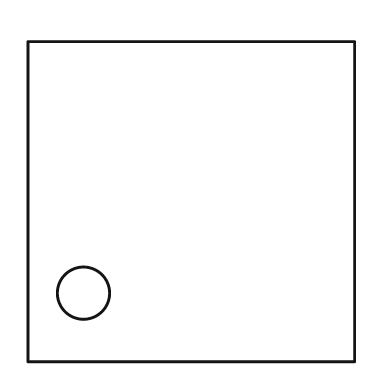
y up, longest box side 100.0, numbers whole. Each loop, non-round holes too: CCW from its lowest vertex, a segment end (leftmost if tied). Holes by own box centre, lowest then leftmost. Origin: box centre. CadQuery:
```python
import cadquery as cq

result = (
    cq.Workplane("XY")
    .moveTo(-50.0, -49.0)
    .lineTo(50.0, -49.0)
    .lineTo(50.0, 49.0)
    .lineTo(-50.0, 49.0)
    .close()
    .moveTo(-33.0, -28.0)
    .circle(8.0)
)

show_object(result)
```